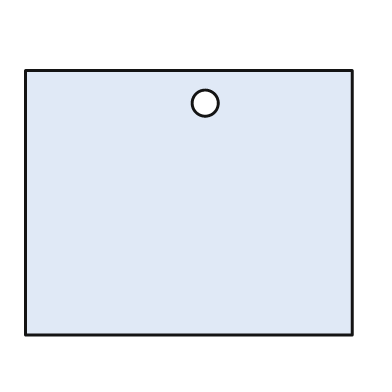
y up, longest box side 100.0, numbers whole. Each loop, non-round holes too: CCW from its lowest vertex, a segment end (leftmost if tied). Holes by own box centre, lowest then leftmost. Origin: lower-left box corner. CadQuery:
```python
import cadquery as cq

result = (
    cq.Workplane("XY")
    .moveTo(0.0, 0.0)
    .lineTo(100.0, 0.0)
    .lineTo(100.0, 81.0)
    .lineTo(0.0, 81.0)
    .close()
    .moveTo(55.0, 71.0)
    .circle(4.0)
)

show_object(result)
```